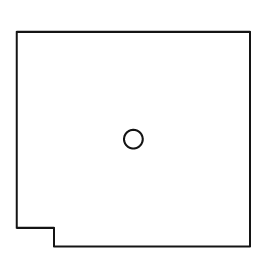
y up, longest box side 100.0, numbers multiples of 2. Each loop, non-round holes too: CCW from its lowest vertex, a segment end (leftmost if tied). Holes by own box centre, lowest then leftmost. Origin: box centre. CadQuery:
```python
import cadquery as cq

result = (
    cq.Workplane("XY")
    .moveTo(-34.0, -46.0)
    .lineTo(50.0, -46.0)
    .lineTo(50.0, 46.0)
    .lineTo(-50.0, 46.0)
    .lineTo(-50.0, -38.0)
    .lineTo(-34.0, -38.0)
    .close()
    .moveTo(0.0, 0.0)
    .circle(4.0)
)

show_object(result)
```